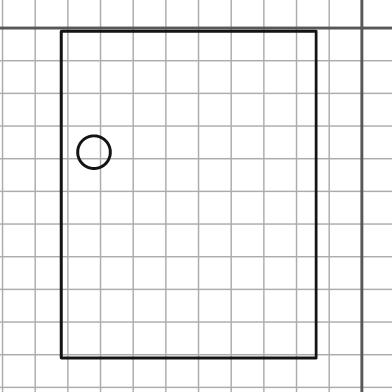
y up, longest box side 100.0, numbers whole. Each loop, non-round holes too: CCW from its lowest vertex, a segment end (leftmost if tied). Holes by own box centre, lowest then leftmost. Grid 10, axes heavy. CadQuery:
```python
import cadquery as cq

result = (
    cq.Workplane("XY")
    .moveTo(-92.0, -101.0)
    .lineTo(-14.0, -101.0)
    .lineTo(-14.0, -1.0)
    .lineTo(-92.0, -1.0)
    .close()
    .moveTo(-82.0, -38.0)
    .circle(5.0)
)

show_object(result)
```